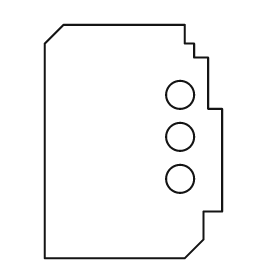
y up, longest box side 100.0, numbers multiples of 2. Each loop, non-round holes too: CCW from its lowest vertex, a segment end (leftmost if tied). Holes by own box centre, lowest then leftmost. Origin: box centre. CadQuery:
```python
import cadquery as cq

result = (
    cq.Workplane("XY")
    .moveTo(-38.0, -50.0)
    .lineTo(22.0, -50.0)
    .lineTo(30.0, -42.0)
    .lineTo(30.0, -30.0)
    .lineTo(38.0, -30.0)
    .lineTo(38.0, 14.0)
    .lineTo(32.0, 14.0)
    .lineTo(32.0, 36.0)
    .lineTo(26.0, 36.0)
    .lineTo(26.0, 42.0)
    .lineTo(22.0, 42.0)
    .lineTo(22.0, 50.0)
    .lineTo(-30.0, 50.0)
    .lineTo(-38.0, 42.0)
    .close()
    .moveTo(20.0, -16.0)
    .circle(6.0)
    .moveTo(20.0, 2.0)
    .circle(6.0)
    .moveTo(20.0, 20.0)
    .circle(6.0)
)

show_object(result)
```